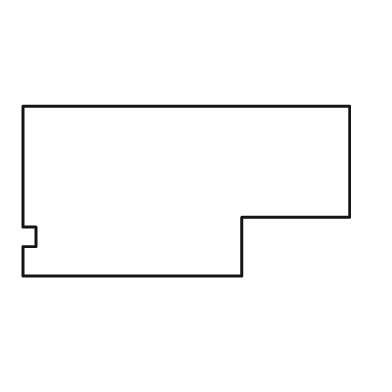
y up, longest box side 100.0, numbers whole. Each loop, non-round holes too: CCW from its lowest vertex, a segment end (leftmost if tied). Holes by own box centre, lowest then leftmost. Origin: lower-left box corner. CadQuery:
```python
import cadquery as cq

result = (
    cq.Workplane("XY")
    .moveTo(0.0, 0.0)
    .lineTo(67.0, 0.0)
    .lineTo(67.0, 18.0)
    .lineTo(100.0, 18.0)
    .lineTo(100.0, 52.0)
    .lineTo(0.0, 52.0)
    .lineTo(0.0, 15.0)
    .lineTo(4.0, 15.0)
    .lineTo(4.0, 9.0)
    .lineTo(0.0, 9.0)
    .close()
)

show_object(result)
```